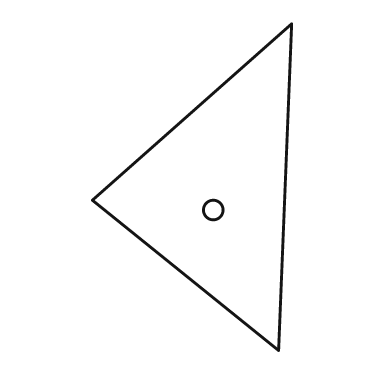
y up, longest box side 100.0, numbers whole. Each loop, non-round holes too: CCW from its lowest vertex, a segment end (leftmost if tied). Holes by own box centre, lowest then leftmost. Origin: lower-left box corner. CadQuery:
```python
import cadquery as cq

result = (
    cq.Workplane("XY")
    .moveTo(57.0, 0.0)
    .lineTo(61.0, 100.0)
    .lineTo(0.0, 46.0)
    .close()
    .moveTo(37.0, 43.0)
    .circle(3.0)
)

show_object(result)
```